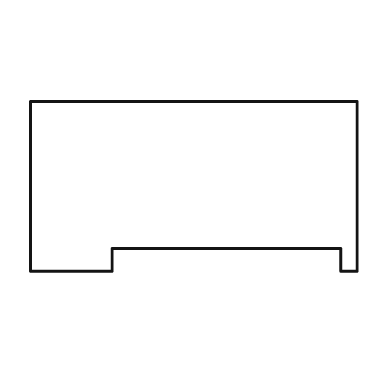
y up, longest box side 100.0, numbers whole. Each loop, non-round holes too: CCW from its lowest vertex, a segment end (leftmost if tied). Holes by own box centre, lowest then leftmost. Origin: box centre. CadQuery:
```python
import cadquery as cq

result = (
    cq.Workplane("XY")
    .moveTo(-50.0, -26.0)
    .lineTo(-25.0, -26.0)
    .lineTo(-25.0, -19.0)
    .lineTo(45.0, -19.0)
    .lineTo(45.0, -26.0)
    .lineTo(50.0, -26.0)
    .lineTo(50.0, 26.0)
    .lineTo(-50.0, 26.0)
    .close()
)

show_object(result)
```